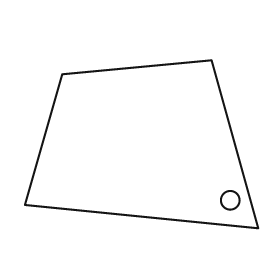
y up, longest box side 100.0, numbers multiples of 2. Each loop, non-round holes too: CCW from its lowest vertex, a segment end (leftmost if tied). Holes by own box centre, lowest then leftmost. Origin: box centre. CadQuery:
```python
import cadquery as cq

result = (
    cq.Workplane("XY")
    .moveTo(50.0, -36.0)
    .lineTo(30.0, 36.0)
    .lineTo(-34.0, 30.0)
    .lineTo(-50.0, -26.0)
    .close()
    .moveTo(38.0, -24.0)
    .circle(4.0)
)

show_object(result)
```